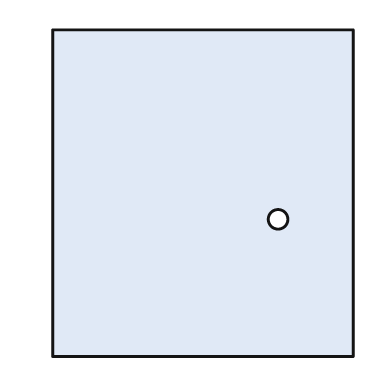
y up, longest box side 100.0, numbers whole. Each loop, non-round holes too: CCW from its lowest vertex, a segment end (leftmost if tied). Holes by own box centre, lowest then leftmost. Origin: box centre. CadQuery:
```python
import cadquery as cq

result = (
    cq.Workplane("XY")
    .moveTo(-46.0, -50.0)
    .lineTo(46.0, -50.0)
    .lineTo(46.0, 50.0)
    .lineTo(-46.0, 50.0)
    .close()
    .moveTo(23.0, -8.0)
    .circle(3.0)
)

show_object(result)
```